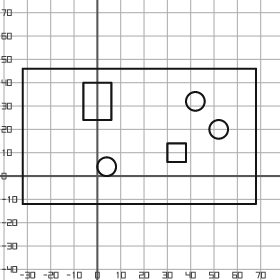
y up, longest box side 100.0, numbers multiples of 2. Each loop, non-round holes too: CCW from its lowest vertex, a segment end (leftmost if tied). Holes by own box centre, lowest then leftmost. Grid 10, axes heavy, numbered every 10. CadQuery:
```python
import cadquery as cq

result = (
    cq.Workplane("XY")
    .moveTo(-32.0, -12.0)
    .lineTo(68.0, -12.0)
    .lineTo(68.0, 46.0)
    .lineTo(-32.0, 46.0)
    .close()
    .moveTo(4.0, 4.0)
    .circle(4.0)
    .moveTo(30.0, 6.0)
    .lineTo(38.0, 6.0)
    .lineTo(38.0, 14.0)
    .lineTo(30.0, 14.0)
    .close()
    .moveTo(52.0, 20.0)
    .circle(4.0)
    .moveTo(-6.0, 24.0)
    .lineTo(6.0, 24.0)
    .lineTo(6.0, 40.0)
    .lineTo(-6.0, 40.0)
    .close()
    .moveTo(42.0, 32.0)
    .circle(4.0)
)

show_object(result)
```